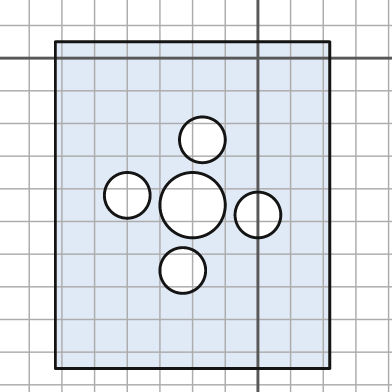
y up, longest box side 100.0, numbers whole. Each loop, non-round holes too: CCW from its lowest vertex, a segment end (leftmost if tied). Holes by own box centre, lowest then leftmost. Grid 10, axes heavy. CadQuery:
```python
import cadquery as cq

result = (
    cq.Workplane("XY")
    .moveTo(-62.0, -95.0)
    .lineTo(22.0, -95.0)
    .lineTo(22.0, 5.0)
    .lineTo(-62.0, 5.0)
    .close()
    .moveTo(-23.0, -65.0)
    .circle(7.0)
    .moveTo(0.0, -48.0)
    .circle(7.0)
    .moveTo(-20.0, -45.0)
    .circle(10.0)
    .moveTo(-40.0, -42.0)
    .circle(7.0)
    .moveTo(-17.0, -25.0)
    .circle(7.0)
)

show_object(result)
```